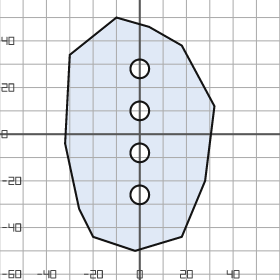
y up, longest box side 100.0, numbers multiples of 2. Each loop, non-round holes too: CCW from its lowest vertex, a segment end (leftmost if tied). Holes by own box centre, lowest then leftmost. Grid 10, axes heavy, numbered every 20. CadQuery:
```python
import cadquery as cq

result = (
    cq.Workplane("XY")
    .moveTo(-2.0, -50.0)
    .lineTo(18.0, -44.0)
    .lineTo(28.0, -20.0)
    .lineTo(32.0, 12.0)
    .lineTo(18.0, 38.0)
    .lineTo(4.0, 46.0)
    .lineTo(-10.0, 50.0)
    .lineTo(-30.0, 34.0)
    .lineTo(-32.0, -4.0)
    .lineTo(-26.0, -32.0)
    .lineTo(-20.0, -44.0)
    .close()
    .moveTo(0.0, -26.0)
    .circle(4.0)
    .moveTo(0.0, -8.0)
    .circle(4.0)
    .moveTo(0.0, 10.0)
    .circle(4.0)
    .moveTo(0.0, 28.0)
    .circle(4.0)
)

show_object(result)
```